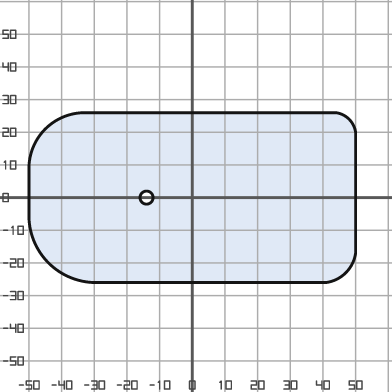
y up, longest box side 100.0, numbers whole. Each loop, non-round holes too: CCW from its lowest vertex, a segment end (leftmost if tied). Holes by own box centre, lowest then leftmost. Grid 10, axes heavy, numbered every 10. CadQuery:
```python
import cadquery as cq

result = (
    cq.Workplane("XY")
    .moveTo(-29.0, -26.0)
    .lineTo(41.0, -26.0)
    .threePointArc((47.0, -23.0), (50.0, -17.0))
    .lineTo(50.0, 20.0)
    .threePointArc((48.0, 24.0), (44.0, 26.0))
    .lineTo(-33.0, 26.0)
    .threePointArc((-45.0, 21.0), (-50.0, 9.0))
    .lineTo(-50.0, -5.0)
    .threePointArc((-44.0, -20.0), (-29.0, -26.0))
    .close()
    .moveTo(-14.0, 0.0)
    .circle(2.0)
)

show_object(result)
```